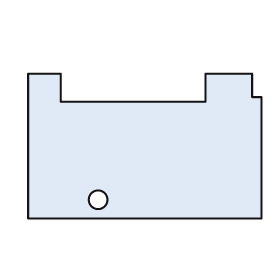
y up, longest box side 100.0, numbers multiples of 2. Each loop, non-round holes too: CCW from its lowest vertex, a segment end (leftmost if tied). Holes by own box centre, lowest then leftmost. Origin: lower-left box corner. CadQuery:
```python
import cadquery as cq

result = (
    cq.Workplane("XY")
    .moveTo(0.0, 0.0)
    .lineTo(100.0, 0.0)
    .lineTo(100.0, 52.0)
    .lineTo(96.0, 52.0)
    .lineTo(96.0, 62.0)
    .lineTo(76.0, 62.0)
    .lineTo(76.0, 50.0)
    .lineTo(14.0, 50.0)
    .lineTo(14.0, 62.0)
    .lineTo(0.0, 62.0)
    .close()
    .moveTo(30.0, 8.0)
    .circle(4.0)
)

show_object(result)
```